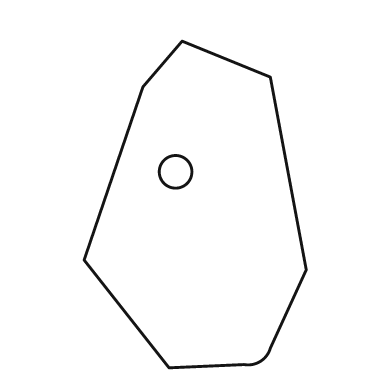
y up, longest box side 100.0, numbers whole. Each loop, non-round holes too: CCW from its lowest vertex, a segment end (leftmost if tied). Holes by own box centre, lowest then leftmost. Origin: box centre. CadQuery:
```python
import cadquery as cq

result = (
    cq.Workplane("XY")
    .moveTo(-8.0, -50.0)
    .lineTo(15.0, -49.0)
    .threePointArc((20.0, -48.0), (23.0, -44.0))
    .lineTo(34.0, -20.0)
    .lineTo(23.0, 39.0)
    .lineTo(-4.0, 50.0)
    .lineTo(-16.0, 36.0)
    .lineTo(-34.0, -17.0)
    .close()
    .moveTo(-6.0, 10.0)
    .circle(5.0)
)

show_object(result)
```